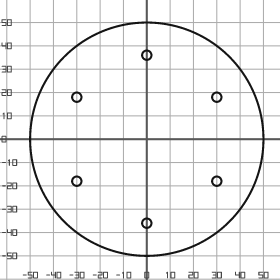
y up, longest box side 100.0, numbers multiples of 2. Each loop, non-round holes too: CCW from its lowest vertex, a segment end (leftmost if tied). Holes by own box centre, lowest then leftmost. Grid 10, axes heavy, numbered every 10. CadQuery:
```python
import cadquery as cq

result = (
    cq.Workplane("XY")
    .moveTo(0.0, 0.0)
    .circle(50.0)
    .moveTo(0.0, -36.0)
    .circle(2.0)
    .moveTo(-30.0, -18.0)
    .circle(2.0)
    .moveTo(30.0, -18.0)
    .circle(2.0)
    .moveTo(-30.0, 18.0)
    .circle(2.0)
    .moveTo(30.0, 18.0)
    .circle(2.0)
    .moveTo(0.0, 36.0)
    .circle(2.0)
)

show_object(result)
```